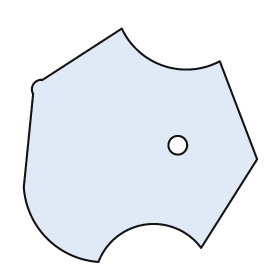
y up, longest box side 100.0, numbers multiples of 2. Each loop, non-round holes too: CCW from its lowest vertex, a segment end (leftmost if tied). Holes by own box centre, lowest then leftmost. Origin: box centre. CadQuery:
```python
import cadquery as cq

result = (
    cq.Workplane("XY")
    .moveTo(-18.0, -50.0)
    .threePointArc((2.0, -34.0), (26.0, -44.0))
    .lineTo(50.0, -6.0)
    .lineTo(34.0, 36.0)
    .threePointArc((10.0, 34.0), (-8.0, 50.0))
    .lineTo(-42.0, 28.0)
    .threePointArc((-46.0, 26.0), (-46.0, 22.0))
    .lineTo(-50.0, -18.0)
    .threePointArc((-40.0, -40.0), (-18.0, -50.0))
    .close()
    .moveTo(16.0, 0.0)
    .circle(4.0)
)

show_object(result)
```